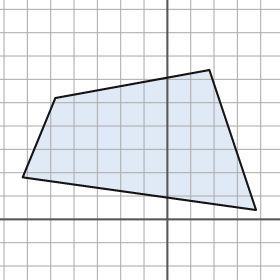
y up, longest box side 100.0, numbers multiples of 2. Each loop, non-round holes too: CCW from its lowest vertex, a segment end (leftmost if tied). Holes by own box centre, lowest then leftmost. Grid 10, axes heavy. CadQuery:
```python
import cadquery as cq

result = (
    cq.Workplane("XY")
    .moveTo(38.0, 4.0)
    .lineTo(18.0, 64.0)
    .lineTo(-48.0, 52.0)
    .lineTo(-62.0, 18.0)
    .close()
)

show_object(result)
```